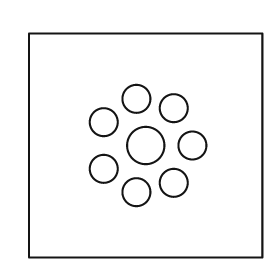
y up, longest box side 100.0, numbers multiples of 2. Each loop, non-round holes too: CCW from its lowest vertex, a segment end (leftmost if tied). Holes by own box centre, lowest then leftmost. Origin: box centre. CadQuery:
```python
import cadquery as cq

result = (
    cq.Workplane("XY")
    .moveTo(-50.0, -48.0)
    .lineTo(50.0, -48.0)
    .lineTo(50.0, 48.0)
    .lineTo(-50.0, 48.0)
    .close()
    .moveTo(-4.0, -20.0)
    .circle(6.0)
    .moveTo(12.0, -16.0)
    .circle(6.0)
    .moveTo(-18.0, -10.0)
    .circle(6.0)
    .moveTo(0.0, 0.0)
    .circle(8.0)
    .moveTo(20.0, 0.0)
    .circle(6.0)
    .moveTo(-18.0, 10.0)
    .circle(6.0)
    .moveTo(12.0, 16.0)
    .circle(6.0)
    .moveTo(-4.0, 20.0)
    .circle(6.0)
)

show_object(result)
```